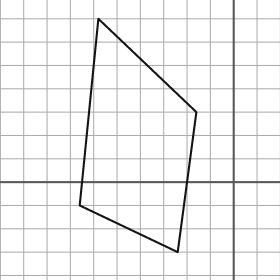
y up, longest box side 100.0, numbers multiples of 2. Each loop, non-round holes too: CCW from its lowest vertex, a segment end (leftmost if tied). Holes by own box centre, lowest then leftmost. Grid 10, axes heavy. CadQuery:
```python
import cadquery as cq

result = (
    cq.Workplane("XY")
    .moveTo(-24.0, -30.0)
    .lineTo(-16.0, 30.0)
    .lineTo(-58.0, 70.0)
    .lineTo(-66.0, -10.0)
    .close()
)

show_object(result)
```